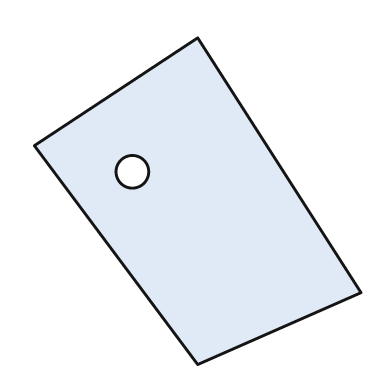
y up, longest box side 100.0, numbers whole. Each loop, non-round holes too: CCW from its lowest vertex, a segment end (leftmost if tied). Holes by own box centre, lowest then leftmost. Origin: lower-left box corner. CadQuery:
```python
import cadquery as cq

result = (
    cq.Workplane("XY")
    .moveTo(50.0, 0.0)
    .lineTo(100.0, 22.0)
    .lineTo(50.0, 100.0)
    .lineTo(0.0, 67.0)
    .close()
    .moveTo(30.0, 59.0)
    .circle(5.0)
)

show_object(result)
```